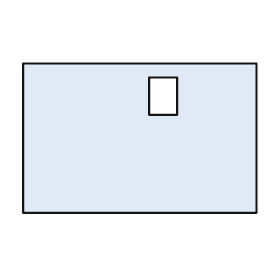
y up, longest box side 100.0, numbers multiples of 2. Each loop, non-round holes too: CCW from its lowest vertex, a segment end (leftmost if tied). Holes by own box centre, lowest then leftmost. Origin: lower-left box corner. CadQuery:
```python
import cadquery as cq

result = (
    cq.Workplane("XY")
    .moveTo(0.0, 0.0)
    .lineTo(100.0, 0.0)
    .lineTo(100.0, 64.0)
    .lineTo(0.0, 64.0)
    .close()
    .moveTo(54.0, 42.0)
    .lineTo(66.0, 42.0)
    .lineTo(66.0, 58.0)
    .lineTo(54.0, 58.0)
    .close()
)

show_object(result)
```